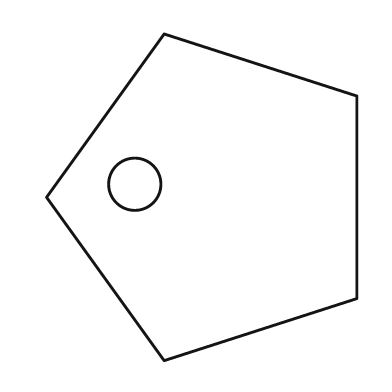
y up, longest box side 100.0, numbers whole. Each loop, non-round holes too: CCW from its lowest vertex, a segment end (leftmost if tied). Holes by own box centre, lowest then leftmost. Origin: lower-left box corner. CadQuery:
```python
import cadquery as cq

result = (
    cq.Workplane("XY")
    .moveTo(36.0, 0.0)
    .lineTo(95.0, 19.0)
    .lineTo(95.0, 81.0)
    .lineTo(36.0, 100.0)
    .lineTo(0.0, 50.0)
    .close()
    .moveTo(27.0, 54.0)
    .circle(8.0)
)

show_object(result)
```